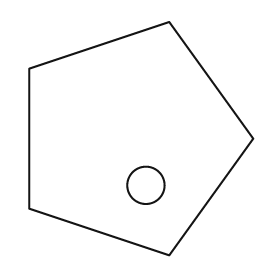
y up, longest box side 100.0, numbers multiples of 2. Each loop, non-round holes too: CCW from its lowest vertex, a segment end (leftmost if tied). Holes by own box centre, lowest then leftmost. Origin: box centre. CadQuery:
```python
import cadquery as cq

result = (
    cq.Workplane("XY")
    .moveTo(12.0, -50.0)
    .lineTo(48.0, 0.0)
    .lineTo(12.0, 50.0)
    .lineTo(-48.0, 30.0)
    .lineTo(-48.0, -30.0)
    .close()
    .moveTo(2.0, -20.0)
    .circle(8.0)
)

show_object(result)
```